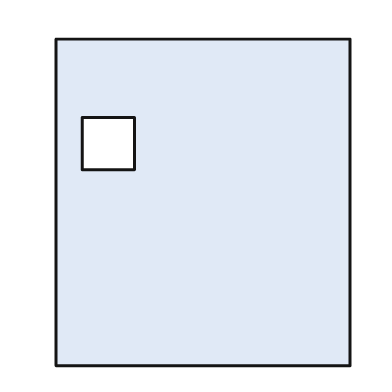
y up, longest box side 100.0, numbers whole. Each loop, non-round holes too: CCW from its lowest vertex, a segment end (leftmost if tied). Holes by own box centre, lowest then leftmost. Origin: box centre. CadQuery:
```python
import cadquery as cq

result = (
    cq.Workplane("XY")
    .moveTo(-45.0, -50.0)
    .lineTo(45.0, -50.0)
    .lineTo(45.0, 50.0)
    .lineTo(-45.0, 50.0)
    .close()
    .moveTo(-37.0, 10.0)
    .lineTo(-21.0, 10.0)
    .lineTo(-21.0, 26.0)
    .lineTo(-37.0, 26.0)
    .close()
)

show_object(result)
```